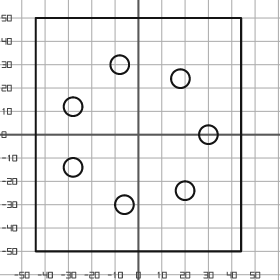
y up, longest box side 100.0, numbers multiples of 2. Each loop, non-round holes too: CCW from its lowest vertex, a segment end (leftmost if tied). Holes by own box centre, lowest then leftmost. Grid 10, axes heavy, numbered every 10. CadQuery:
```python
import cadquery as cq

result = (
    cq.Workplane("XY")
    .moveTo(-44.0, -50.0)
    .lineTo(44.0, -50.0)
    .lineTo(44.0, 50.0)
    .lineTo(-44.0, 50.0)
    .close()
    .moveTo(-6.0, -30.0)
    .circle(4.0)
    .moveTo(20.0, -24.0)
    .circle(4.0)
    .moveTo(-28.0, -14.0)
    .circle(4.0)
    .moveTo(30.0, 0.0)
    .circle(4.0)
    .moveTo(-28.0, 12.0)
    .circle(4.0)
    .moveTo(18.0, 24.0)
    .circle(4.0)
    .moveTo(-8.0, 30.0)
    .circle(4.0)
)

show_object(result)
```